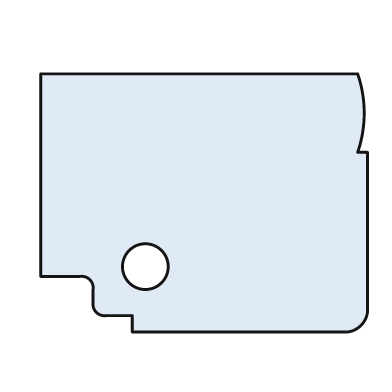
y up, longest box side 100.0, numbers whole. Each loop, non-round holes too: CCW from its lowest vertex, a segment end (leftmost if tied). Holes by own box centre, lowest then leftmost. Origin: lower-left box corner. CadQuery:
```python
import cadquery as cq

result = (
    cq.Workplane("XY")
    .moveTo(28.0, 0.0)
    .lineTo(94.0, 0.0)
    .threePointArc((98.0, 2.0), (100.0, 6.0))
    .lineTo(100.0, 55.0)
    .lineTo(97.0, 55.0)
    .threePointArc((99.0, 67.0), (97.0, 79.0))
    .lineTo(0.0, 79.0)
    .lineTo(0.0, 17.0)
    .lineTo(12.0, 17.0)
    .threePointArc((15.0, 16.0), (16.0, 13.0))
    .lineTo(16.0, 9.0)
    .threePointArc((17.0, 6.0), (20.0, 5.0))
    .lineTo(28.0, 5.0)
    .close()
    .moveTo(32.0, 20.0)
    .circle(7.0)
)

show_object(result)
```